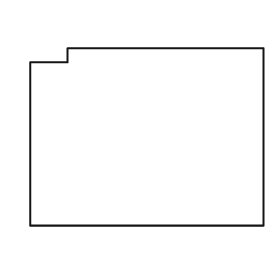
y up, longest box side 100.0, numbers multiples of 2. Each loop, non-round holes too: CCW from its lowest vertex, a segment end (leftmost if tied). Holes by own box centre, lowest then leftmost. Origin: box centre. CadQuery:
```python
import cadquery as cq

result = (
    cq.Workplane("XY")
    .moveTo(-50.0, -38.0)
    .lineTo(50.0, -38.0)
    .lineTo(50.0, 38.0)
    .lineTo(-34.0, 38.0)
    .lineTo(-34.0, 32.0)
    .lineTo(-50.0, 32.0)
    .close()
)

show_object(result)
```